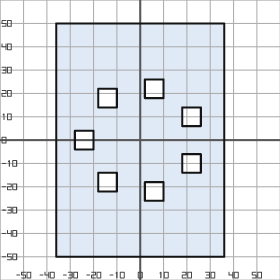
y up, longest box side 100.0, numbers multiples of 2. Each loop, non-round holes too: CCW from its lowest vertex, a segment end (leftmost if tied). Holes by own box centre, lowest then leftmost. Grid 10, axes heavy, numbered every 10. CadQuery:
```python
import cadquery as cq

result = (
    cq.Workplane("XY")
    .moveTo(-36.0, -50.0)
    .lineTo(36.0, -50.0)
    .lineTo(36.0, 50.0)
    .lineTo(-36.0, 50.0)
    .close()
    .moveTo(2.0, -26.0)
    .lineTo(10.0, -26.0)
    .lineTo(10.0, -18.0)
    .lineTo(2.0, -18.0)
    .close()
    .moveTo(-18.0, -22.0)
    .lineTo(-10.0, -22.0)
    .lineTo(-10.0, -14.0)
    .lineTo(-18.0, -14.0)
    .close()
    .moveTo(18.0, -14.0)
    .lineTo(26.0, -14.0)
    .lineTo(26.0, -6.0)
    .lineTo(18.0, -6.0)
    .close()
    .moveTo(-28.0, -4.0)
    .lineTo(-20.0, -4.0)
    .lineTo(-20.0, 4.0)
    .lineTo(-28.0, 4.0)
    .close()
    .moveTo(18.0, 6.0)
    .lineTo(26.0, 6.0)
    .lineTo(26.0, 14.0)
    .lineTo(18.0, 14.0)
    .close()
    .moveTo(-18.0, 14.0)
    .lineTo(-10.0, 14.0)
    .lineTo(-10.0, 22.0)
    .lineTo(-18.0, 22.0)
    .close()
    .moveTo(2.0, 18.0)
    .lineTo(10.0, 18.0)
    .lineTo(10.0, 26.0)
    .lineTo(2.0, 26.0)
    .close()
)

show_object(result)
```